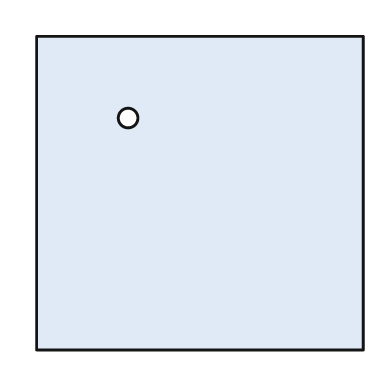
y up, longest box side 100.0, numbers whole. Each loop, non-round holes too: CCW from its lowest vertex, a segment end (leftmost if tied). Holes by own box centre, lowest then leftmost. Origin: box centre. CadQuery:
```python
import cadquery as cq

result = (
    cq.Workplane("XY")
    .moveTo(-50.0, -48.0)
    .lineTo(50.0, -48.0)
    .lineTo(50.0, 48.0)
    .lineTo(-50.0, 48.0)
    .close()
    .moveTo(-22.0, 23.0)
    .circle(3.0)
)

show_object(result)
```